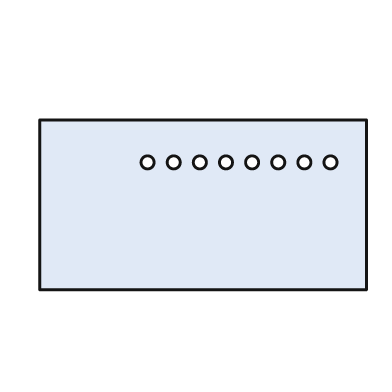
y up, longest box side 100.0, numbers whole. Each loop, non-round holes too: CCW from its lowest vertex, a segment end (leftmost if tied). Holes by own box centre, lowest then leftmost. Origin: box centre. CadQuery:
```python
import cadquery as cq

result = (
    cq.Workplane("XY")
    .moveTo(-50.0, -26.0)
    .lineTo(50.0, -26.0)
    .lineTo(50.0, 26.0)
    .lineTo(-50.0, 26.0)
    .close()
    .moveTo(-17.0, 13.0)
    .circle(2.0)
    .moveTo(-9.0, 13.0)
    .circle(2.0)
    .moveTo(-1.0, 13.0)
    .circle(2.0)
    .moveTo(7.0, 13.0)
    .circle(2.0)
    .moveTo(15.0, 13.0)
    .circle(2.0)
    .moveTo(23.0, 13.0)
    .circle(2.0)
    .moveTo(31.0, 13.0)
    .circle(2.0)
    .moveTo(39.0, 13.0)
    .circle(2.0)
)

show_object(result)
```